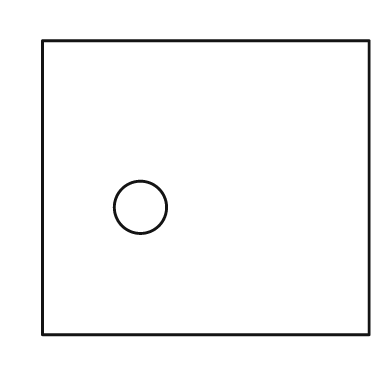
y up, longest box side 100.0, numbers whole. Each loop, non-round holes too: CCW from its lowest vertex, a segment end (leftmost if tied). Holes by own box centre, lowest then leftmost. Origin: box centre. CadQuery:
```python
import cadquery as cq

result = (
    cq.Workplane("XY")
    .moveTo(-50.0, -45.0)
    .lineTo(50.0, -45.0)
    .lineTo(50.0, 45.0)
    .lineTo(-50.0, 45.0)
    .close()
    .moveTo(-20.0, -6.0)
    .circle(8.0)
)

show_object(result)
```